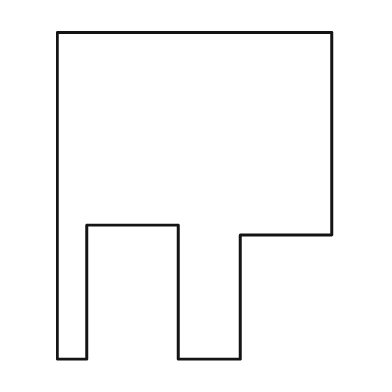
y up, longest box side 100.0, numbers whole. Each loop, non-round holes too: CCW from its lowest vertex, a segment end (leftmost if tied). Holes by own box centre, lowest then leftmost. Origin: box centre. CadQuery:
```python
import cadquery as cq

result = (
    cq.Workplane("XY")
    .moveTo(-42.0, -50.0)
    .lineTo(-33.0, -50.0)
    .lineTo(-33.0, -9.0)
    .lineTo(-5.0, -9.0)
    .lineTo(-5.0, -50.0)
    .lineTo(14.0, -50.0)
    .lineTo(14.0, -12.0)
    .lineTo(42.0, -12.0)
    .lineTo(42.0, 50.0)
    .lineTo(-42.0, 50.0)
    .close()
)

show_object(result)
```